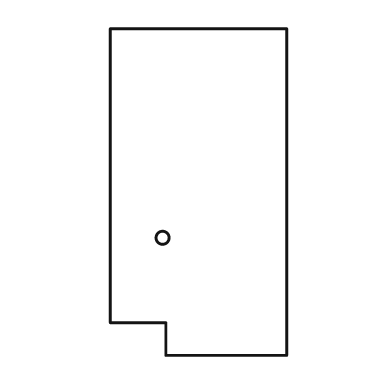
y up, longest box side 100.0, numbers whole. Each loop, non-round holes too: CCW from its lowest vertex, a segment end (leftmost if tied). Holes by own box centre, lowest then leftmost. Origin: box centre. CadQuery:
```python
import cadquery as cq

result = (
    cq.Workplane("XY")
    .moveTo(-10.0, -50.0)
    .lineTo(27.0, -50.0)
    .lineTo(27.0, 50.0)
    .lineTo(-27.0, 50.0)
    .lineTo(-27.0, -40.0)
    .lineTo(-10.0, -40.0)
    .close()
    .moveTo(-11.0, -14.0)
    .circle(2.0)
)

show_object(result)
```